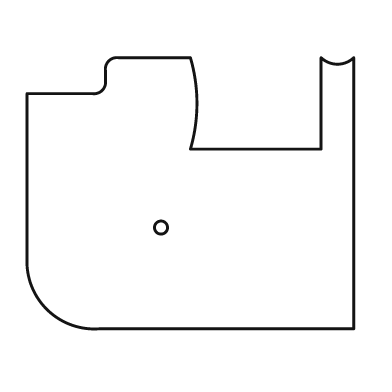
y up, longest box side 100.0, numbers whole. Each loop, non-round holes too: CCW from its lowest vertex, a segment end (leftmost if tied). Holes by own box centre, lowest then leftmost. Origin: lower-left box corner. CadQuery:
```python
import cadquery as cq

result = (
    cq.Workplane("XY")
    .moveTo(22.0, 0.0)
    .lineTo(100.0, 0.0)
    .lineTo(100.0, 83.0)
    .threePointArc((95.0, 81.0), (90.0, 83.0))
    .lineTo(90.0, 55.0)
    .lineTo(50.0, 55.0)
    .threePointArc((52.0, 69.0), (50.0, 83.0))
    .lineTo(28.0, 83.0)
    .threePointArc((25.0, 82.0), (24.0, 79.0))
    .lineTo(24.0, 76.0)
    .threePointArc((23.0, 73.0), (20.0, 72.0))
    .lineTo(0.0, 72.0)
    .lineTo(0.0, 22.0)
    .threePointArc((6.0, 6.0), (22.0, 0.0))
    .close()
    .moveTo(41.0, 31.0)
    .circle(2.0)
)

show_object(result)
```